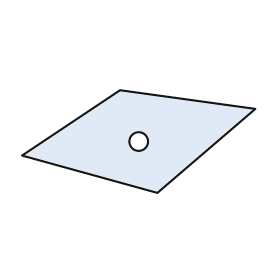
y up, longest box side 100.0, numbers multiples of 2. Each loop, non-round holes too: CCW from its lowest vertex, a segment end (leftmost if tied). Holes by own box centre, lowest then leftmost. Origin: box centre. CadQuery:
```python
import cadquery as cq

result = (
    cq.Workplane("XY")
    .moveTo(8.0, -22.0)
    .lineTo(50.0, 14.0)
    .lineTo(-8.0, 22.0)
    .lineTo(-50.0, -6.0)
    .close()
    .moveTo(0.0, 0.0)
    .circle(4.0)
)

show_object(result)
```